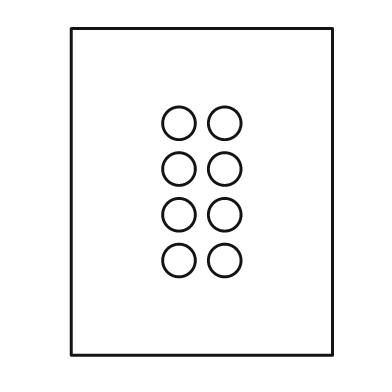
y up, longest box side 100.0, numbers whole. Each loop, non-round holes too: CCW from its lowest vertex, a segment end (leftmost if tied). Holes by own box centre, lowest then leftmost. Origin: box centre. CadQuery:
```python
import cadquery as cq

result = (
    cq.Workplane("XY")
    .moveTo(-40.0, -50.0)
    .lineTo(40.0, -50.0)
    .lineTo(40.0, 50.0)
    .lineTo(-40.0, 50.0)
    .close()
    .moveTo(-7.0, -21.0)
    .circle(5.0)
    .moveTo(7.0, -21.0)
    .circle(5.0)
    .moveTo(-7.0, -7.0)
    .circle(5.0)
    .moveTo(7.0, -7.0)
    .circle(5.0)
    .moveTo(-7.0, 7.0)
    .circle(5.0)
    .moveTo(7.0, 7.0)
    .circle(5.0)
    .moveTo(-7.0, 21.0)
    .circle(5.0)
    .moveTo(7.0, 21.0)
    .circle(5.0)
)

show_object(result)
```